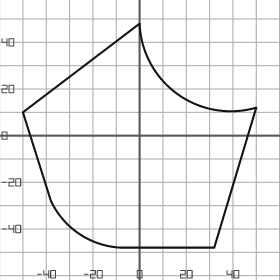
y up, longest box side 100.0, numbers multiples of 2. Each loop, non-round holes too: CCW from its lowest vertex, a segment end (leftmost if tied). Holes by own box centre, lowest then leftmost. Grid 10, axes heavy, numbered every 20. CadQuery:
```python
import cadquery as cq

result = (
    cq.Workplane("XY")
    .moveTo(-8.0, -48.0)
    .lineTo(32.0, -48.0)
    .lineTo(50.0, 12.0)
    .threePointArc((16.0, 18.0), (0.0, 48.0))
    .lineTo(-50.0, 10.0)
    .lineTo(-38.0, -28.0)
    .threePointArc((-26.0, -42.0), (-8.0, -48.0))
    .close()
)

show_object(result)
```